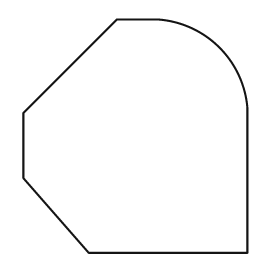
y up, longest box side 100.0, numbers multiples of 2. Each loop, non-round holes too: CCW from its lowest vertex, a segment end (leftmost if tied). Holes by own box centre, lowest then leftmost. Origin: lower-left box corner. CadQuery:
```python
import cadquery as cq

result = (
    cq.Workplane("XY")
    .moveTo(28.0, 0.0)
    .lineTo(96.0, 0.0)
    .lineTo(96.0, 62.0)
    .threePointArc((84.0, 88.0), (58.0, 100.0))
    .lineTo(40.0, 100.0)
    .lineTo(0.0, 60.0)
    .lineTo(0.0, 32.0)
    .close()
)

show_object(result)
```